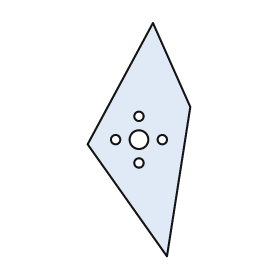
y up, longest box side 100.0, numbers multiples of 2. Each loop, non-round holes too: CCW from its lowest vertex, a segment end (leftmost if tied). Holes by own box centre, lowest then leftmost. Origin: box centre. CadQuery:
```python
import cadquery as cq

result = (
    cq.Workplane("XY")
    .moveTo(12.0, -50.0)
    .lineTo(22.0, 14.0)
    .lineTo(6.0, 50.0)
    .lineTo(-22.0, -2.0)
    .close()
    .moveTo(0.0, -10.0)
    .circle(2.0)
    .moveTo(-10.0, 0.0)
    .circle(2.0)
    .moveTo(0.0, 0.0)
    .circle(4.0)
    .moveTo(10.0, 0.0)
    .circle(2.0)
    .moveTo(0.0, 10.0)
    .circle(2.0)
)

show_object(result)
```